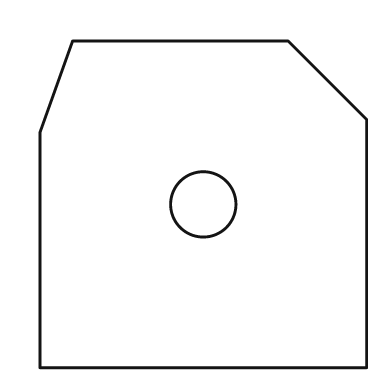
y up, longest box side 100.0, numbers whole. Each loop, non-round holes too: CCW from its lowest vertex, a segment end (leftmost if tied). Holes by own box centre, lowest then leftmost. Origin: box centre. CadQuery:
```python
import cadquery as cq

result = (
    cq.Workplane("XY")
    .moveTo(-50.0, -50.0)
    .lineTo(50.0, -50.0)
    .lineTo(50.0, 26.0)
    .lineTo(26.0, 50.0)
    .lineTo(-40.0, 50.0)
    .lineTo(-50.0, 22.0)
    .close()
    .moveTo(0.0, 0.0)
    .circle(10.0)
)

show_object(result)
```